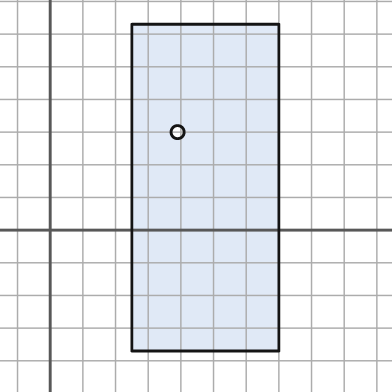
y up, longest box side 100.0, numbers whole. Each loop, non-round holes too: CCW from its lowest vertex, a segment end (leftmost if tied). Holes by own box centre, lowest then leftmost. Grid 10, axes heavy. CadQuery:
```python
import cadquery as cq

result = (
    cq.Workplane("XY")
    .moveTo(25.0, -37.0)
    .lineTo(70.0, -37.0)
    .lineTo(70.0, 63.0)
    .lineTo(25.0, 63.0)
    .close()
    .moveTo(39.0, 30.0)
    .circle(2.0)
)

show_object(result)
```